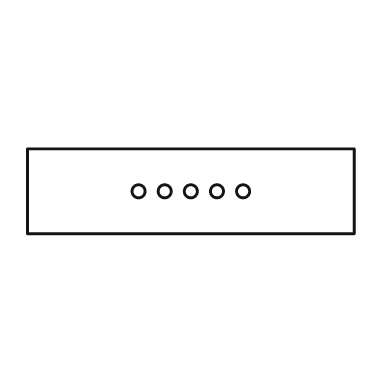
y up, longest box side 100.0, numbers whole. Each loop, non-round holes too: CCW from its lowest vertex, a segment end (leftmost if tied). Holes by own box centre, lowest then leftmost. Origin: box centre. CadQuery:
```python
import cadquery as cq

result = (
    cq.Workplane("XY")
    .moveTo(-50.0, -13.0)
    .lineTo(50.0, -13.0)
    .lineTo(50.0, 13.0)
    .lineTo(-50.0, 13.0)
    .close()
    .moveTo(-16.0, 0.0)
    .circle(2.0)
    .moveTo(-8.0, 0.0)
    .circle(2.0)
    .moveTo(0.0, 0.0)
    .circle(2.0)
    .moveTo(8.0, 0.0)
    .circle(2.0)
    .moveTo(16.0, 0.0)
    .circle(2.0)
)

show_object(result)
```